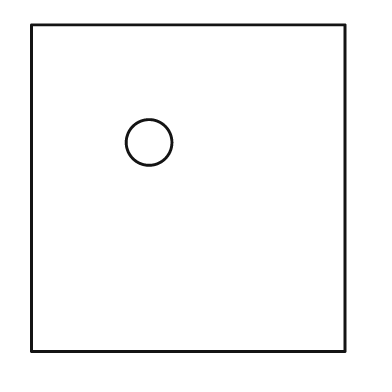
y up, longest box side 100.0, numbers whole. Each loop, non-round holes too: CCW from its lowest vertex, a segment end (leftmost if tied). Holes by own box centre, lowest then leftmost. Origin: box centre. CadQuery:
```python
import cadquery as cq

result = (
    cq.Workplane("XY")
    .moveTo(-48.0, -50.0)
    .lineTo(48.0, -50.0)
    .lineTo(48.0, 50.0)
    .lineTo(-48.0, 50.0)
    .close()
    .moveTo(-12.0, 14.0)
    .circle(7.0)
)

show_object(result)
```